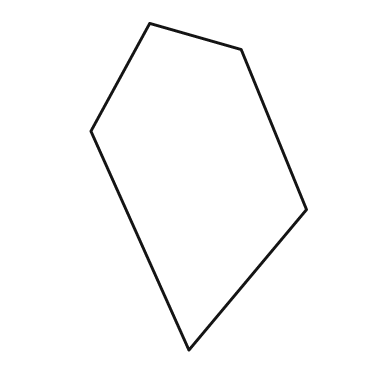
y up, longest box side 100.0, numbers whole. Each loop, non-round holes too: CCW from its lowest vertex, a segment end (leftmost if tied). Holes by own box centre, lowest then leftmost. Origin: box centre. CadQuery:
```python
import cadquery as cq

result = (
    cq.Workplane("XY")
    .moveTo(-3.0, -50.0)
    .lineTo(33.0, -7.0)
    .lineTo(13.0, 42.0)
    .lineTo(-15.0, 50.0)
    .lineTo(-33.0, 17.0)
    .close()
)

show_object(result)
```